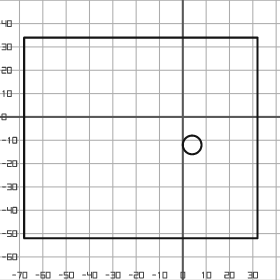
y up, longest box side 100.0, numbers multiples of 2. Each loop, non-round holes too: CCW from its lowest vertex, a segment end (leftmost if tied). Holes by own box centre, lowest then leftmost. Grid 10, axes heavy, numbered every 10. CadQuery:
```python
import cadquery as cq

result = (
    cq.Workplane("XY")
    .moveTo(-68.0, -52.0)
    .lineTo(32.0, -52.0)
    .lineTo(32.0, 34.0)
    .lineTo(-68.0, 34.0)
    .close()
    .moveTo(4.0, -12.0)
    .circle(4.0)
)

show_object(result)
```